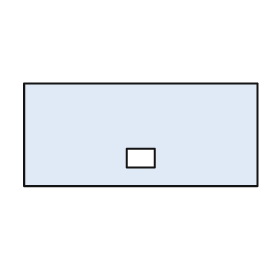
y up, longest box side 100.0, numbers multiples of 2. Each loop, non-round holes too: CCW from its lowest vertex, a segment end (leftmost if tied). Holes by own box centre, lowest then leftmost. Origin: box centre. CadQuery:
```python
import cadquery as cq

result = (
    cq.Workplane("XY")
    .moveTo(-50.0, -22.0)
    .lineTo(50.0, -22.0)
    .lineTo(50.0, 22.0)
    .lineTo(-50.0, 22.0)
    .close()
    .moveTo(-6.0, -14.0)
    .lineTo(6.0, -14.0)
    .lineTo(6.0, -6.0)
    .lineTo(-6.0, -6.0)
    .close()
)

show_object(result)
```